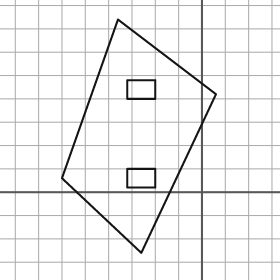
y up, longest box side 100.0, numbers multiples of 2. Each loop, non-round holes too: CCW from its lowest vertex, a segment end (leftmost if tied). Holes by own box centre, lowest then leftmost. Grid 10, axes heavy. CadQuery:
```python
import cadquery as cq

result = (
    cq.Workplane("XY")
    .moveTo(-26.0, -26.0)
    .lineTo(6.0, 42.0)
    .lineTo(-36.0, 74.0)
    .lineTo(-60.0, 6.0)
    .close()
    .moveTo(-32.0, 2.0)
    .lineTo(-20.0, 2.0)
    .lineTo(-20.0, 10.0)
    .lineTo(-32.0, 10.0)
    .close()
    .moveTo(-32.0, 40.0)
    .lineTo(-20.0, 40.0)
    .lineTo(-20.0, 48.0)
    .lineTo(-32.0, 48.0)
    .close()
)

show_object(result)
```